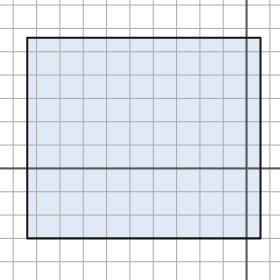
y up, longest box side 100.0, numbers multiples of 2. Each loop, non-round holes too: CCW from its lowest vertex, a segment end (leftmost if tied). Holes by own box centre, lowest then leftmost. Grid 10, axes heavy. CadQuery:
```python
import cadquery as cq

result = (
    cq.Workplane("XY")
    .moveTo(-94.0, -30.0)
    .lineTo(6.0, -30.0)
    .lineTo(6.0, 56.0)
    .lineTo(-94.0, 56.0)
    .close()
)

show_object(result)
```